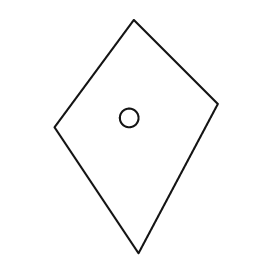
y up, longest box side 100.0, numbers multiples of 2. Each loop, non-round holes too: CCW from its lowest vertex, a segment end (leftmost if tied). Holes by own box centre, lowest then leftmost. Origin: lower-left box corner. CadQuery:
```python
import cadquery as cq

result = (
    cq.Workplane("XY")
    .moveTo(36.0, 0.0)
    .lineTo(70.0, 64.0)
    .lineTo(34.0, 100.0)
    .lineTo(0.0, 54.0)
    .close()
    .moveTo(32.0, 58.0)
    .circle(4.0)
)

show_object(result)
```